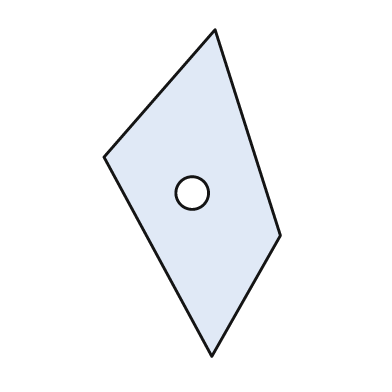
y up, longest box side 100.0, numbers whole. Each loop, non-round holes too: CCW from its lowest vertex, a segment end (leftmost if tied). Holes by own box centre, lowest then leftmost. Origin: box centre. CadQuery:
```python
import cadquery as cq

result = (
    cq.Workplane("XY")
    .moveTo(6.0, -50.0)
    .lineTo(27.0, -13.0)
    .lineTo(7.0, 50.0)
    .lineTo(-27.0, 11.0)
    .close()
    .moveTo(0.0, 0.0)
    .circle(5.0)
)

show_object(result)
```